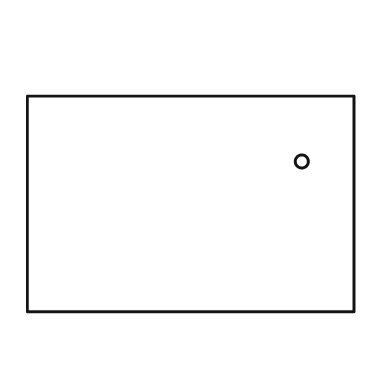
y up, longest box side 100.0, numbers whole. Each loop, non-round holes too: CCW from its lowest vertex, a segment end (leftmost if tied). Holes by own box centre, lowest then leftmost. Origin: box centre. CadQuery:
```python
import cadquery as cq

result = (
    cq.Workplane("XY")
    .moveTo(-50.0, -33.0)
    .lineTo(50.0, -33.0)
    .lineTo(50.0, 33.0)
    .lineTo(-50.0, 33.0)
    .close()
    .moveTo(34.0, 13.0)
    .circle(2.0)
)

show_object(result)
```